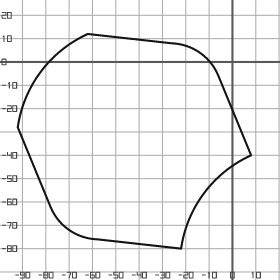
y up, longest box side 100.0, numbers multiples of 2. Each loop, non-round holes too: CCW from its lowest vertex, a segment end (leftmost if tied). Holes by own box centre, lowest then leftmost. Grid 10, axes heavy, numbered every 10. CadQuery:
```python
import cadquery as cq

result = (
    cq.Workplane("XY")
    .moveTo(-22.0, -80.0)
    .threePointArc((-12.0, -56.0), (8.0, -40.0))
    .lineTo(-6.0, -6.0)
    .threePointArc((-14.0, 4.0), (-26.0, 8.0))
    .lineTo(-62.0, 12.0)
    .threePointArc((-82.0, -4.0), (-92.0, -28.0))
    .lineTo(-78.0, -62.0)
    .threePointArc((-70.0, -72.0), (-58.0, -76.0))
    .close()
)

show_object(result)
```